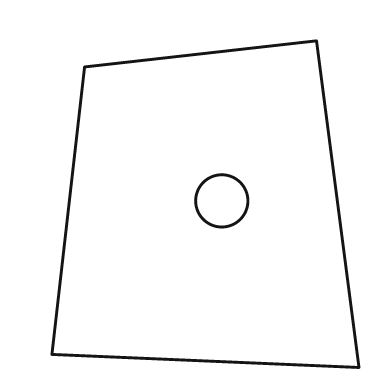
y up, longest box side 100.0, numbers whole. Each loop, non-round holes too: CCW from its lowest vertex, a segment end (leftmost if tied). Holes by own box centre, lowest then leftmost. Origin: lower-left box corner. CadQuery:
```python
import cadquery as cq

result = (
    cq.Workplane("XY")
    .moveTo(94.0, 0.0)
    .lineTo(81.0, 100.0)
    .lineTo(10.0, 92.0)
    .lineTo(0.0, 4.0)
    .close()
    .moveTo(52.0, 51.0)
    .circle(8.0)
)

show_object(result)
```